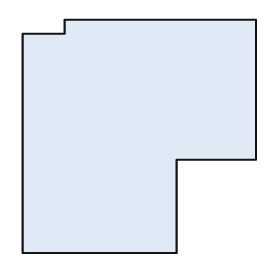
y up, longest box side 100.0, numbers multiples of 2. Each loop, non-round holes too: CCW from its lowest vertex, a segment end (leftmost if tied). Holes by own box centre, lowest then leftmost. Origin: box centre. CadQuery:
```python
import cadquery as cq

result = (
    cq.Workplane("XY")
    .moveTo(-50.0, -50.0)
    .lineTo(16.0, -50.0)
    .lineTo(16.0, -10.0)
    .lineTo(50.0, -10.0)
    .lineTo(50.0, 50.0)
    .lineTo(-32.0, 50.0)
    .lineTo(-32.0, 44.0)
    .lineTo(-50.0, 44.0)
    .close()
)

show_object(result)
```